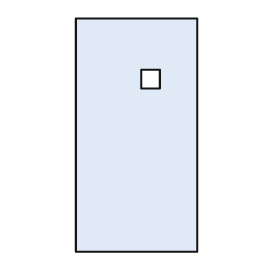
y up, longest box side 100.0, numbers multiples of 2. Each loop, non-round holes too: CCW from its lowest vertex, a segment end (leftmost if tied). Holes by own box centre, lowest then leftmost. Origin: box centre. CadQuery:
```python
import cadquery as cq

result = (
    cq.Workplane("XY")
    .moveTo(-26.0, -50.0)
    .lineTo(26.0, -50.0)
    .lineTo(26.0, 50.0)
    .lineTo(-26.0, 50.0)
    .close()
    .moveTo(2.0, 20.0)
    .lineTo(10.0, 20.0)
    .lineTo(10.0, 28.0)
    .lineTo(2.0, 28.0)
    .close()
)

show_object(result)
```